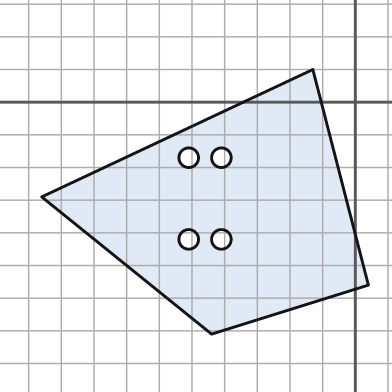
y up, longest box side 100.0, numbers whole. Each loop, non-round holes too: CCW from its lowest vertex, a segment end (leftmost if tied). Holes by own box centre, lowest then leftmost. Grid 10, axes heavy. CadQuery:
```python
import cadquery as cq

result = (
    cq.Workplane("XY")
    .moveTo(-44.0, -71.0)
    .lineTo(4.0, -56.0)
    .lineTo(-13.0, 10.0)
    .lineTo(-96.0, -29.0)
    .close()
    .moveTo(-51.0, -42.0)
    .circle(3.0)
    .moveTo(-41.0, -42.0)
    .circle(3.0)
    .moveTo(-51.0, -17.0)
    .circle(3.0)
    .moveTo(-41.0, -17.0)
    .circle(3.0)
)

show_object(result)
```